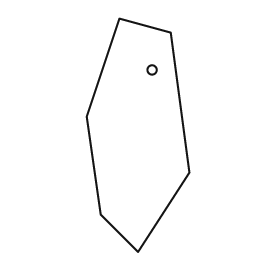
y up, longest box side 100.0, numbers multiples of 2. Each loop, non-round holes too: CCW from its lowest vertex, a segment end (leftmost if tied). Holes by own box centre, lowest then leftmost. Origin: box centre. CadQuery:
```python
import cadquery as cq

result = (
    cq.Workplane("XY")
    .moveTo(0.0, -50.0)
    .lineTo(22.0, -16.0)
    .lineTo(14.0, 44.0)
    .lineTo(-8.0, 50.0)
    .lineTo(-22.0, 8.0)
    .lineTo(-16.0, -34.0)
    .close()
    .moveTo(6.0, 28.0)
    .circle(2.0)
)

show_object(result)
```